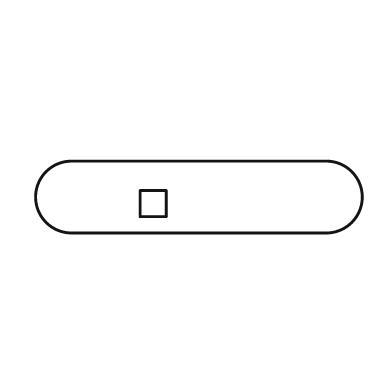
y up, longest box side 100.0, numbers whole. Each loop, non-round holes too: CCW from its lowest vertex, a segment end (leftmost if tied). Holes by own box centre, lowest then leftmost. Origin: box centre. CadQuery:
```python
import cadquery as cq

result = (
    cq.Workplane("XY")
    .moveTo(-39.0, -11.0)
    .lineTo(39.0, -11.0)
    .threePointArc((50.0, 0.0), (39.0, 11.0))
    .lineTo(-39.0, 11.0)
    .threePointArc((-50.0, 0.0), (-39.0, -11.0))
    .close()
    .moveTo(-18.0, -6.0)
    .lineTo(-10.0, -6.0)
    .lineTo(-10.0, 2.0)
    .lineTo(-18.0, 2.0)
    .close()
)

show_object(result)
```